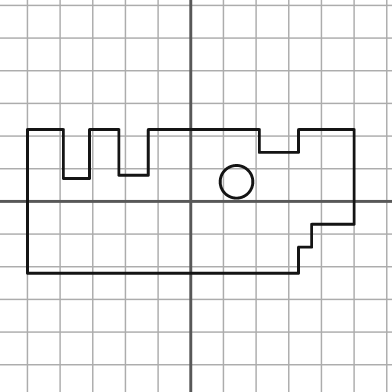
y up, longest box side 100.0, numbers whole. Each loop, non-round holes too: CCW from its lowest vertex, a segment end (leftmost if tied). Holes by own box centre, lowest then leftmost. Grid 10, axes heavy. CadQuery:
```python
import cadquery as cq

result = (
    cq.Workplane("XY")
    .moveTo(-50.0, -22.0)
    .lineTo(33.0, -22.0)
    .lineTo(33.0, -14.0)
    .lineTo(37.0, -14.0)
    .lineTo(37.0, -7.0)
    .lineTo(50.0, -7.0)
    .lineTo(50.0, 22.0)
    .lineTo(33.0, 22.0)
    .lineTo(33.0, 15.0)
    .lineTo(21.0, 15.0)
    .lineTo(21.0, 22.0)
    .lineTo(-13.0, 22.0)
    .lineTo(-13.0, 8.0)
    .lineTo(-22.0, 8.0)
    .lineTo(-22.0, 22.0)
    .lineTo(-31.0, 22.0)
    .lineTo(-31.0, 7.0)
    .lineTo(-39.0, 7.0)
    .lineTo(-39.0, 22.0)
    .lineTo(-50.0, 22.0)
    .close()
    .moveTo(14.0, 6.0)
    .circle(5.0)
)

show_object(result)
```